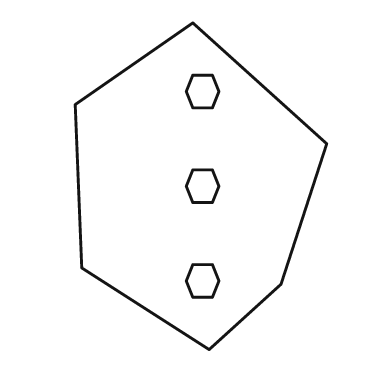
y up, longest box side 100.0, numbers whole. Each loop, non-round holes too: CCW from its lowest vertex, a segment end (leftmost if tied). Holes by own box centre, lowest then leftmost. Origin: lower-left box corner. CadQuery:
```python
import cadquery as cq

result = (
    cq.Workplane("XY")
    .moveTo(41.0, 0.0)
    .lineTo(63.0, 20.0)
    .lineTo(77.0, 63.0)
    .lineTo(36.0, 100.0)
    .lineTo(0.0, 75.0)
    .lineTo(2.0, 25.0)
    .close()
    .moveTo(36.0, 16.0)
    .lineTo(42.0, 16.0)
    .lineTo(44.0, 21.0)
    .lineTo(42.0, 26.0)
    .lineTo(36.0, 26.0)
    .lineTo(34.0, 21.0)
    .close()
    .moveTo(36.0, 45.0)
    .lineTo(42.0, 45.0)
    .lineTo(44.0, 50.0)
    .lineTo(42.0, 55.0)
    .lineTo(36.0, 55.0)
    .lineTo(34.0, 50.0)
    .close()
    .moveTo(36.0, 74.0)
    .lineTo(42.0, 74.0)
    .lineTo(44.0, 79.0)
    .lineTo(42.0, 84.0)
    .lineTo(36.0, 84.0)
    .lineTo(34.0, 79.0)
    .close()
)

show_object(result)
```